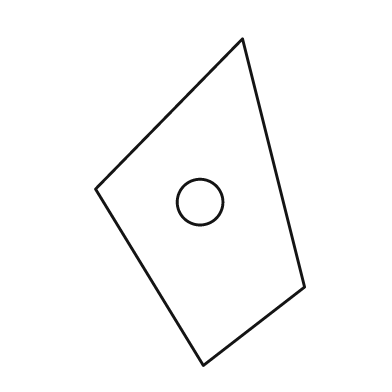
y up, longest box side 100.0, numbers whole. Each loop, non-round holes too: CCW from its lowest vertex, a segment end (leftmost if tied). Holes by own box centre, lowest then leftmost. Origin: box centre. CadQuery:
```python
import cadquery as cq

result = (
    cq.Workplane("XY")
    .moveTo(1.0, -50.0)
    .lineTo(32.0, -26.0)
    .lineTo(13.0, 50.0)
    .lineTo(-32.0, 4.0)
    .close()
    .moveTo(0.0, 0.0)
    .circle(7.0)
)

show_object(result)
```